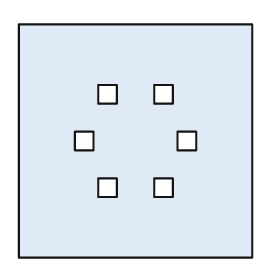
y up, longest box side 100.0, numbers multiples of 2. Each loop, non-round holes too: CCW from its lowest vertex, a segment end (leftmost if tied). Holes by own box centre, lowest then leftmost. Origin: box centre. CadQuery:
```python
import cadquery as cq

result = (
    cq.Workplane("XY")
    .moveTo(-50.0, -50.0)
    .lineTo(50.0, -50.0)
    .lineTo(50.0, 50.0)
    .lineTo(-50.0, 50.0)
    .close()
    .moveTo(-16.0, -24.0)
    .lineTo(-8.0, -24.0)
    .lineTo(-8.0, -16.0)
    .lineTo(-16.0, -16.0)
    .close()
    .moveTo(8.0, -24.0)
    .lineTo(16.0, -24.0)
    .lineTo(16.0, -16.0)
    .lineTo(8.0, -16.0)
    .close()
    .moveTo(-26.0, -4.0)
    .lineTo(-18.0, -4.0)
    .lineTo(-18.0, 4.0)
    .lineTo(-26.0, 4.0)
    .close()
    .moveTo(18.0, -4.0)
    .lineTo(26.0, -4.0)
    .lineTo(26.0, 4.0)
    .lineTo(18.0, 4.0)
    .close()
    .moveTo(-16.0, 16.0)
    .lineTo(-8.0, 16.0)
    .lineTo(-8.0, 24.0)
    .lineTo(-16.0, 24.0)
    .close()
    .moveTo(8.0, 16.0)
    .lineTo(16.0, 16.0)
    .lineTo(16.0, 24.0)
    .lineTo(8.0, 24.0)
    .close()
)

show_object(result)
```